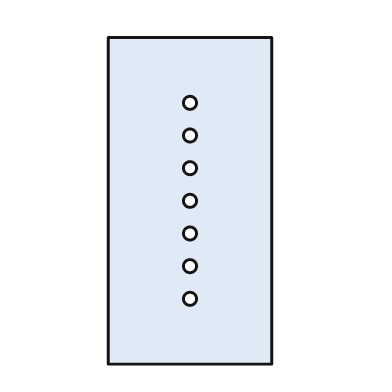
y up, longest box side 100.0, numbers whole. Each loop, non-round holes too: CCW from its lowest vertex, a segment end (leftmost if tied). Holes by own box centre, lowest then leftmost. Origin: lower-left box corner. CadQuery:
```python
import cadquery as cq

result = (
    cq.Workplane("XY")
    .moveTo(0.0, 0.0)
    .lineTo(50.0, 0.0)
    .lineTo(50.0, 100.0)
    .lineTo(0.0, 100.0)
    .close()
    .moveTo(25.0, 20.0)
    .circle(2.0)
    .moveTo(25.0, 30.0)
    .circle(2.0)
    .moveTo(25.0, 40.0)
    .circle(2.0)
    .moveTo(25.0, 50.0)
    .circle(2.0)
    .moveTo(25.0, 60.0)
    .circle(2.0)
    .moveTo(25.0, 70.0)
    .circle(2.0)
    .moveTo(25.0, 80.0)
    .circle(2.0)
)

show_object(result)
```